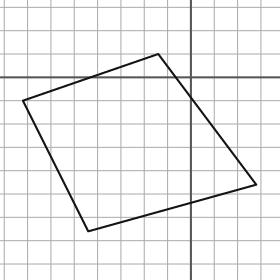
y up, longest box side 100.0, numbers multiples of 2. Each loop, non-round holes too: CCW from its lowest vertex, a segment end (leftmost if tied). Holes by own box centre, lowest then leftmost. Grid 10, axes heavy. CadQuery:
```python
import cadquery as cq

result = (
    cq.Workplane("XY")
    .moveTo(-44.0, -66.0)
    .lineTo(28.0, -46.0)
    .lineTo(-14.0, 10.0)
    .lineTo(-72.0, -10.0)
    .close()
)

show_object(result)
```